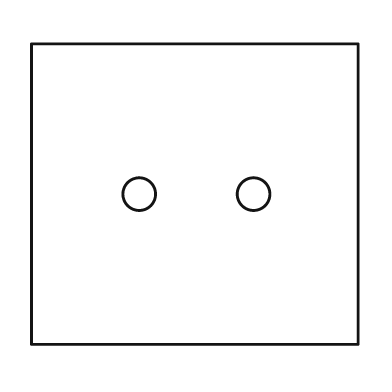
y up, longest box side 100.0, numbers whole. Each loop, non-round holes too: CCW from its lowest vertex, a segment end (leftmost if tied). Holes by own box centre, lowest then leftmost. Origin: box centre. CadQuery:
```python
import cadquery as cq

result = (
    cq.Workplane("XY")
    .moveTo(-50.0, -46.0)
    .lineTo(50.0, -46.0)
    .lineTo(50.0, 46.0)
    .lineTo(-50.0, 46.0)
    .close()
    .moveTo(-17.0, 0.0)
    .circle(5.0)
    .moveTo(18.0, 0.0)
    .circle(5.0)
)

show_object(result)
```